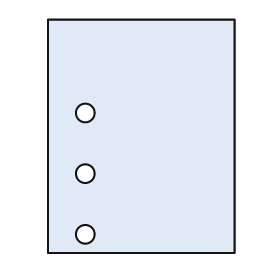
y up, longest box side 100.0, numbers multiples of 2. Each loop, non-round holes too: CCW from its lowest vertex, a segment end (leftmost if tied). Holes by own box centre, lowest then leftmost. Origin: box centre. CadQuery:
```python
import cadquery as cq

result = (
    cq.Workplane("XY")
    .moveTo(-40.0, -50.0)
    .lineTo(40.0, -50.0)
    .lineTo(40.0, 50.0)
    .lineTo(-40.0, 50.0)
    .close()
    .moveTo(-24.0, -42.0)
    .circle(4.0)
    .moveTo(-24.0, -16.0)
    .circle(4.0)
    .moveTo(-24.0, 10.0)
    .circle(4.0)
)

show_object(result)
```